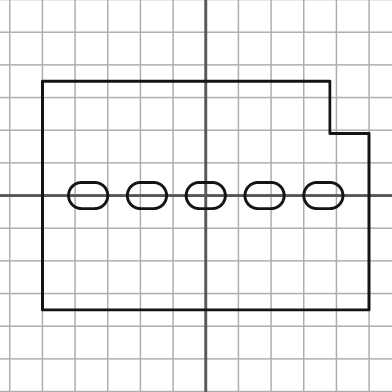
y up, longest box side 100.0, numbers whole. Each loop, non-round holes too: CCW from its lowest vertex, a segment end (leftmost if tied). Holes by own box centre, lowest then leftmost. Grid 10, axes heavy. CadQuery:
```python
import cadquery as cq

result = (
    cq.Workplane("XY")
    .moveTo(-50.0, -35.0)
    .lineTo(50.0, -35.0)
    .lineTo(50.0, 19.0)
    .lineTo(38.0, 19.0)
    .lineTo(38.0, 35.0)
    .lineTo(-50.0, 35.0)
    .close()
    .moveTo(-38.0, -4.0)
    .lineTo(-34.0, -4.0)
    .threePointArc((-30.0, 0.0), (-34.0, 4.0))
    .lineTo(-38.0, 4.0)
    .threePointArc((-42.0, 0.0), (-38.0, -4.0))
    .close()
    .moveTo(-20.0, -4.0)
    .lineTo(-16.0, -4.0)
    .threePointArc((-12.0, 0.0), (-16.0, 4.0))
    .lineTo(-20.0, 4.0)
    .threePointArc((-24.0, 0.0), (-20.0, -4.0))
    .close()
    .moveTo(-2.0, -4.0)
    .lineTo(2.0, -4.0)
    .threePointArc((6.0, 0.0), (2.0, 4.0))
    .lineTo(-2.0, 4.0)
    .threePointArc((-6.0, 0.0), (-2.0, -4.0))
    .close()
    .moveTo(16.0, -4.0)
    .lineTo(20.0, -4.0)
    .threePointArc((24.0, 0.0), (20.0, 4.0))
    .lineTo(16.0, 4.0)
    .threePointArc((12.0, 0.0), (16.0, -4.0))
    .close()
    .moveTo(34.0, -4.0)
    .lineTo(38.0, -4.0)
    .threePointArc((42.0, 0.0), (38.0, 4.0))
    .lineTo(34.0, 4.0)
    .threePointArc((30.0, 0.0), (34.0, -4.0))
    .close()
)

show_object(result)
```